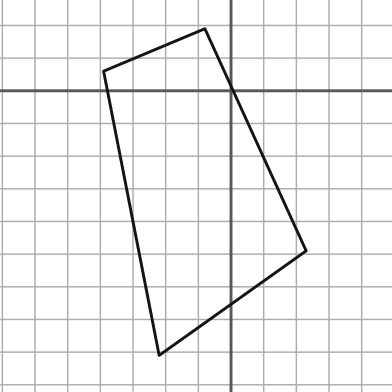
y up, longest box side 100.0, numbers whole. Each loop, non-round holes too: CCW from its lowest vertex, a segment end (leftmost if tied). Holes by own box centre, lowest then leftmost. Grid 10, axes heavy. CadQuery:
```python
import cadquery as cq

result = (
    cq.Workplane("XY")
    .moveTo(-22.0, -81.0)
    .lineTo(23.0, -49.0)
    .lineTo(-8.0, 19.0)
    .lineTo(-39.0, 6.0)
    .close()
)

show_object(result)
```